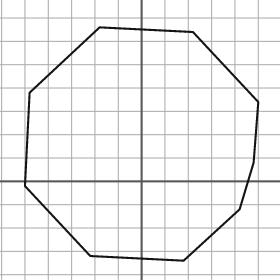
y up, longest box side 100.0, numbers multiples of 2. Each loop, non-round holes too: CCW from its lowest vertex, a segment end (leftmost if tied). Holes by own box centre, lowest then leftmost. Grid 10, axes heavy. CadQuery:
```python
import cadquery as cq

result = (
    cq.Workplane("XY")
    .moveTo(18.0, -34.0)
    .lineTo(42.0, -12.0)
    .lineTo(48.0, 8.0)
    .lineTo(50.0, 34.0)
    .lineTo(22.0, 64.0)
    .lineTo(-18.0, 66.0)
    .lineTo(-48.0, 38.0)
    .lineTo(-50.0, -2.0)
    .lineTo(-22.0, -32.0)
    .close()
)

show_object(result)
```